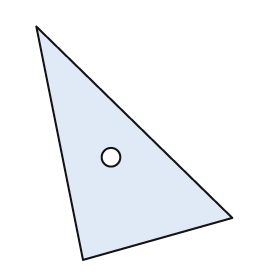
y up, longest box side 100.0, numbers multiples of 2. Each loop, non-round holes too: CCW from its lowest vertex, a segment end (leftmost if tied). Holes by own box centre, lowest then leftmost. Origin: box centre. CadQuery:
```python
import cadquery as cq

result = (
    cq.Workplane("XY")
    .moveTo(-22.0, -50.0)
    .lineTo(42.0, -32.0)
    .lineTo(-42.0, 50.0)
    .close()
    .moveTo(-10.0, -6.0)
    .circle(4.0)
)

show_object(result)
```